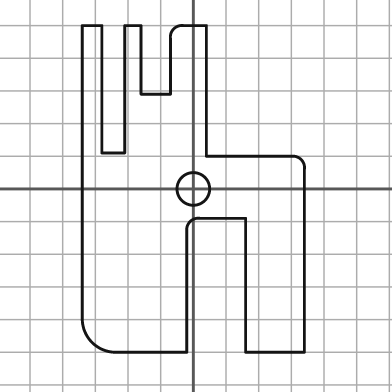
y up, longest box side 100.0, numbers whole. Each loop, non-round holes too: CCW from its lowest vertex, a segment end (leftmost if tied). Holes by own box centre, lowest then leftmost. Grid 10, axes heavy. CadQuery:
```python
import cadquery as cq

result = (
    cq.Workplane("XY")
    .moveTo(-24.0, -50.0)
    .lineTo(-2.0, -50.0)
    .lineTo(-2.0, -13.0)
    .threePointArc((-1.0, -10.0), (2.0, -9.0))
    .lineTo(16.0, -9.0)
    .lineTo(16.0, -50.0)
    .lineTo(34.0, -50.0)
    .lineTo(34.0, 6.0)
    .threePointArc((33.0, 9.0), (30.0, 10.0))
    .lineTo(4.0, 10.0)
    .lineTo(4.0, 50.0)
    .lineTo(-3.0, 50.0)
    .threePointArc((-6.0, 49.0), (-7.0, 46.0))
    .lineTo(-7.0, 29.0)
    .lineTo(-16.0, 29.0)
    .lineTo(-16.0, 50.0)
    .lineTo(-21.0, 50.0)
    .lineTo(-21.0, 11.0)
    .lineTo(-28.0, 11.0)
    .lineTo(-28.0, 50.0)
    .lineTo(-34.0, 50.0)
    .lineTo(-34.0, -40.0)
    .threePointArc((-31.0, -47.0), (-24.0, -50.0))
    .close()
    .moveTo(0.0, 0.0)
    .circle(5.0)
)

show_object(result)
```